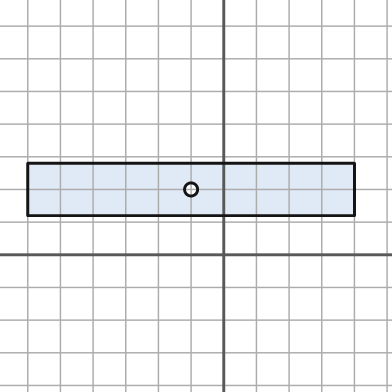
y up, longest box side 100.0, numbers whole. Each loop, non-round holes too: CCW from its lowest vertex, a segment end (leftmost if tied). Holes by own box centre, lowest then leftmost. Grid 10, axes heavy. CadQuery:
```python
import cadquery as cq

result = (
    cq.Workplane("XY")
    .moveTo(-60.0, 12.0)
    .lineTo(40.0, 12.0)
    .lineTo(40.0, 28.0)
    .lineTo(-60.0, 28.0)
    .close()
    .moveTo(-10.0, 20.0)
    .circle(2.0)
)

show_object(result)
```